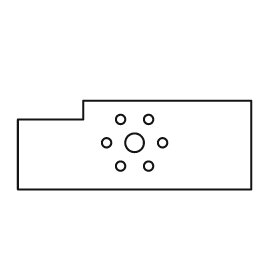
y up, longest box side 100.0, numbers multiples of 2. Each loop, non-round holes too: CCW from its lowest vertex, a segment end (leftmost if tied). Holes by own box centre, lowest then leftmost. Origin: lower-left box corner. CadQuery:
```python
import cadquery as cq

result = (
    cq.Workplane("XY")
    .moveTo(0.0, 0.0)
    .lineTo(100.0, 0.0)
    .lineTo(100.0, 38.0)
    .lineTo(28.0, 38.0)
    .lineTo(28.0, 30.0)
    .lineTo(0.0, 30.0)
    .close()
    .moveTo(44.0, 10.0)
    .circle(2.0)
    .moveTo(56.0, 10.0)
    .circle(2.0)
    .moveTo(38.0, 20.0)
    .circle(2.0)
    .moveTo(50.0, 20.0)
    .circle(4.0)
    .moveTo(62.0, 20.0)
    .circle(2.0)
    .moveTo(44.0, 30.0)
    .circle(2.0)
    .moveTo(56.0, 30.0)
    .circle(2.0)
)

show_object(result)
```